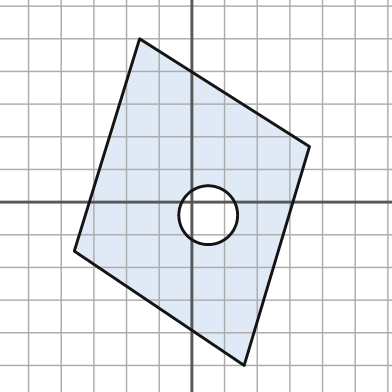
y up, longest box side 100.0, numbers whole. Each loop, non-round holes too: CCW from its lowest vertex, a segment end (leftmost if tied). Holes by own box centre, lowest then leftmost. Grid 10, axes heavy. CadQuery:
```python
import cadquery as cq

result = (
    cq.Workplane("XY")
    .moveTo(16.0, -50.0)
    .lineTo(36.0, 17.0)
    .lineTo(-16.0, 50.0)
    .lineTo(-36.0, -15.0)
    .close()
    .moveTo(5.0, -4.0)
    .circle(9.0)
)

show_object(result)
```